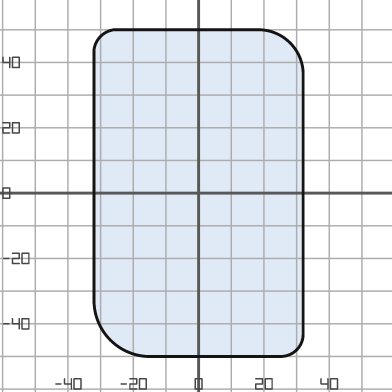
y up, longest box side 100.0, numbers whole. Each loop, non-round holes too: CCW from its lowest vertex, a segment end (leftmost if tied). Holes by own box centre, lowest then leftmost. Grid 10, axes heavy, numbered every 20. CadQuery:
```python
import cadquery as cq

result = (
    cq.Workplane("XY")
    .moveTo(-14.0, -50.0)
    .lineTo(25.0, -50.0)
    .threePointArc((30.0, -48.0), (32.0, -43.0))
    .lineTo(32.0, 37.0)
    .threePointArc((28.0, 46.0), (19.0, 50.0))
    .lineTo(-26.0, 50.0)
    .threePointArc((-30.0, 48.0), (-32.0, 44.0))
    .lineTo(-32.0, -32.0)
    .threePointArc((-27.0, -45.0), (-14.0, -50.0))
    .close()
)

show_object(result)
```